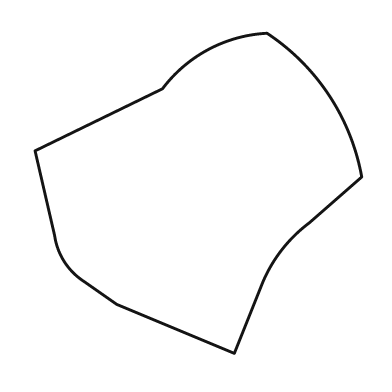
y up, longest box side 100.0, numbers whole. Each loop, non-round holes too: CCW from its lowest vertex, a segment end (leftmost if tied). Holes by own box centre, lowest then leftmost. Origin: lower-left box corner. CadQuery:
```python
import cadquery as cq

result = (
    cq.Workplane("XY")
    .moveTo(61.0, 0.0)
    .lineTo(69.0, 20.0)
    .threePointArc((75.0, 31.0), (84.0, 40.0))
    .lineTo(100.0, 54.0)
    .threePointArc((90.0, 79.0), (71.0, 98.0))
    .threePointArc((53.0, 93.0), (39.0, 81.0))
    .lineTo(0.0, 62.0)
    .lineTo(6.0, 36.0)
    .threePointArc((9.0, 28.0), (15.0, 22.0))
    .lineTo(25.0, 15.0)
    .close()
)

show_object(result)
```